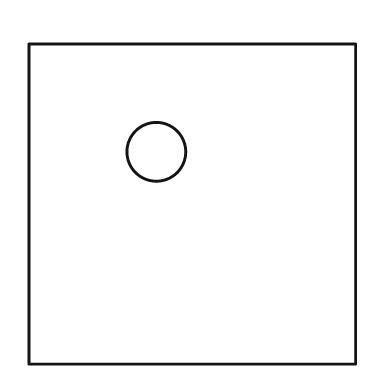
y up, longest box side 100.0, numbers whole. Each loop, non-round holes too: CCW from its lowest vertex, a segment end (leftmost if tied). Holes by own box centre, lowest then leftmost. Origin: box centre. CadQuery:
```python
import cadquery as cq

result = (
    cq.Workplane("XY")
    .moveTo(-50.0, -49.0)
    .lineTo(50.0, -49.0)
    .lineTo(50.0, 49.0)
    .lineTo(-50.0, 49.0)
    .close()
    .moveTo(-11.0, 16.0)
    .circle(9.0)
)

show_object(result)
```